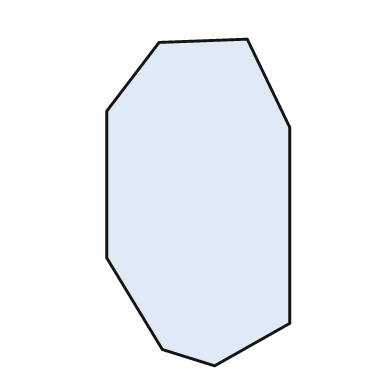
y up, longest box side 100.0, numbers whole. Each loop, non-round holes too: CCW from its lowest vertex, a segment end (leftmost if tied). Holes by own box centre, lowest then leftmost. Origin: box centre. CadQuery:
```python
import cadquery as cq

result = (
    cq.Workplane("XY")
    .moveTo(5.0, -50.0)
    .lineTo(28.0, -37.0)
    .lineTo(28.0, 23.0)
    .lineTo(15.0, 50.0)
    .lineTo(-12.0, 49.0)
    .lineTo(-28.0, 28.0)
    .lineTo(-28.0, -17.0)
    .lineTo(-11.0, -45.0)
    .close()
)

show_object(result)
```